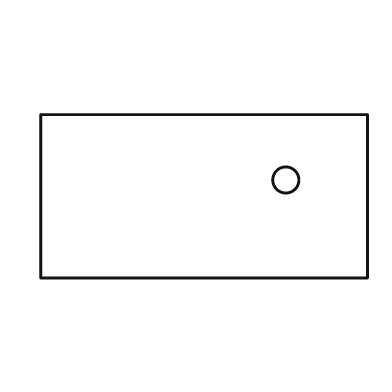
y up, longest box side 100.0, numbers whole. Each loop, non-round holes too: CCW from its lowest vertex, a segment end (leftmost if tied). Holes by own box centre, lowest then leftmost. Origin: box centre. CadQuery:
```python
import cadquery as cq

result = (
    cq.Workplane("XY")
    .moveTo(-50.0, -25.0)
    .lineTo(50.0, -25.0)
    .lineTo(50.0, 25.0)
    .lineTo(-50.0, 25.0)
    .close()
    .moveTo(25.0, 5.0)
    .circle(4.0)
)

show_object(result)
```